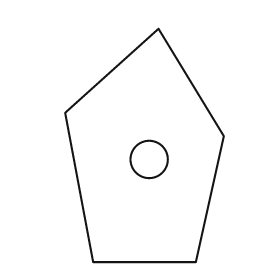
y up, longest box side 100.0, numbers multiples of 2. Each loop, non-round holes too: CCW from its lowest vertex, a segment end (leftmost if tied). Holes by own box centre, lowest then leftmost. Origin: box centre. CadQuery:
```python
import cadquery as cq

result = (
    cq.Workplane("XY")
    .moveTo(-22.0, -50.0)
    .lineTo(22.0, -50.0)
    .lineTo(34.0, 4.0)
    .lineTo(6.0, 50.0)
    .lineTo(-34.0, 14.0)
    .close()
    .moveTo(2.0, -6.0)
    .circle(8.0)
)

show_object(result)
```